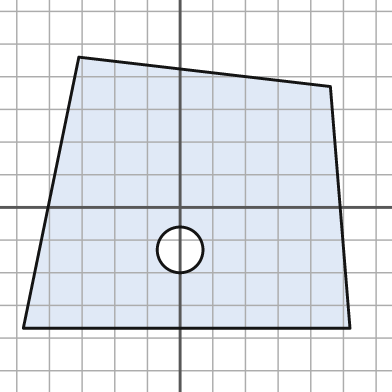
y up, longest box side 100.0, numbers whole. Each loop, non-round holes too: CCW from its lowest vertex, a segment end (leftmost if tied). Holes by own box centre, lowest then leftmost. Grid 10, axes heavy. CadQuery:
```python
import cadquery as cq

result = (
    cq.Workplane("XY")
    .moveTo(-48.0, -37.0)
    .lineTo(52.0, -37.0)
    .lineTo(46.0, 37.0)
    .lineTo(-31.0, 46.0)
    .close()
    .moveTo(0.0, -13.0)
    .circle(7.0)
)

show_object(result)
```